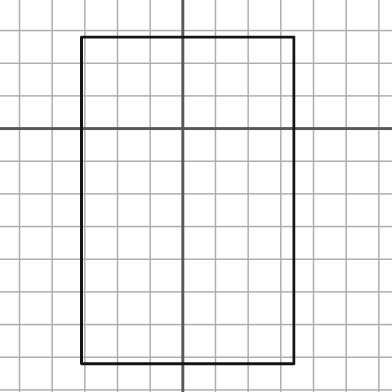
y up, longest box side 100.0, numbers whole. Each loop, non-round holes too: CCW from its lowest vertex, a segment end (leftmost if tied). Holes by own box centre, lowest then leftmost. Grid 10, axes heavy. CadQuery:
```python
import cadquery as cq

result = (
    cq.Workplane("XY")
    .moveTo(-31.0, -72.0)
    .lineTo(34.0, -72.0)
    .lineTo(34.0, 28.0)
    .lineTo(-31.0, 28.0)
    .close()
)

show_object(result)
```